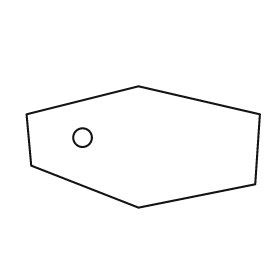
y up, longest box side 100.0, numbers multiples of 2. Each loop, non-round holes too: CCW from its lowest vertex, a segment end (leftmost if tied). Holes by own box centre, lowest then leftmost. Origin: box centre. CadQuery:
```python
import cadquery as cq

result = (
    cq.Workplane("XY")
    .moveTo(-2.0, -26.0)
    .lineTo(48.0, -16.0)
    .lineTo(50.0, 14.0)
    .lineTo(-2.0, 26.0)
    .lineTo(-50.0, 14.0)
    .lineTo(-48.0, -8.0)
    .close()
    .moveTo(-26.0, 4.0)
    .circle(4.0)
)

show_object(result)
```